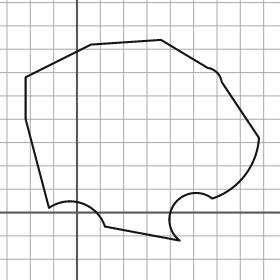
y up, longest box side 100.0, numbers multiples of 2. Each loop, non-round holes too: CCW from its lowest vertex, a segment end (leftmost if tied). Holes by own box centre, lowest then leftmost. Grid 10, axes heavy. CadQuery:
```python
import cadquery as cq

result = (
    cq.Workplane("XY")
    .moveTo(44.0, -12.0)
    .threePointArc((42.0, 4.0), (58.0, 6.0))
    .threePointArc((72.0, 16.0), (78.0, 32.0))
    .lineTo(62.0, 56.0)
    .threePointArc((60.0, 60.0), (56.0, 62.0))
    .lineTo(36.0, 74.0)
    .lineTo(6.0, 72.0)
    .lineTo(-22.0, 58.0)
    .lineTo(-22.0, 40.0)
    .lineTo(-12.0, 2.0)
    .threePointArc((2.0, 4.0), (12.0, -6.0))
    .close()
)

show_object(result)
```